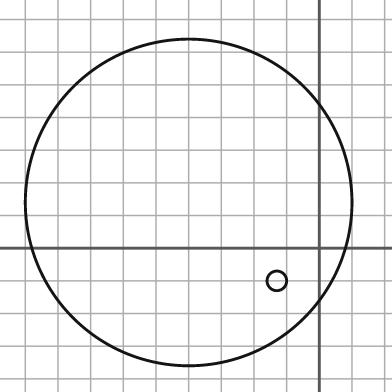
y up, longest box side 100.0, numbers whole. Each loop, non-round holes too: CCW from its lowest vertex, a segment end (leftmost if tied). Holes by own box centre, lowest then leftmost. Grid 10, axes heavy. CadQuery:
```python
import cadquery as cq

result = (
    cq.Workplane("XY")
    .moveTo(-40.0, 14.0)
    .circle(50.0)
    .moveTo(-13.0, -10.0)
    .circle(3.0)
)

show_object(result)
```